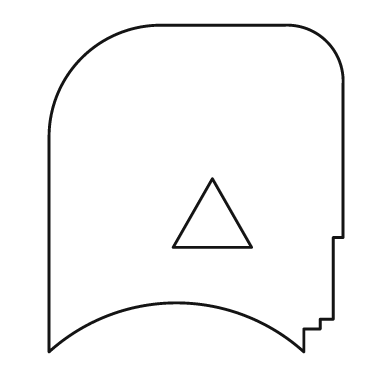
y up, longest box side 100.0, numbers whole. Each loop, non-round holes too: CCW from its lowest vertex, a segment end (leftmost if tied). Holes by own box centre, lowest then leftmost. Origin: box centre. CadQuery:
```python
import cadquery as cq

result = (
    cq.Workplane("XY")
    .moveTo(-45.0, -50.0)
    .threePointArc((-6.0, -35.0), (33.0, -50.0))
    .lineTo(33.0, -43.0)
    .lineTo(38.0, -43.0)
    .lineTo(38.0, -40.0)
    .lineTo(42.0, -40.0)
    .lineTo(42.0, -15.0)
    .lineTo(45.0, -15.0)
    .lineTo(45.0, 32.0)
    .threePointArc((40.0, 45.0), (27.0, 50.0))
    .lineTo(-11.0, 50.0)
    .threePointArc((-35.0, 40.0), (-45.0, 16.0))
    .close()
    .moveTo(-7.0, -18.0)
    .lineTo(17.0, -18.0)
    .lineTo(5.0, 3.0)
    .close()
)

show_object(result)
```